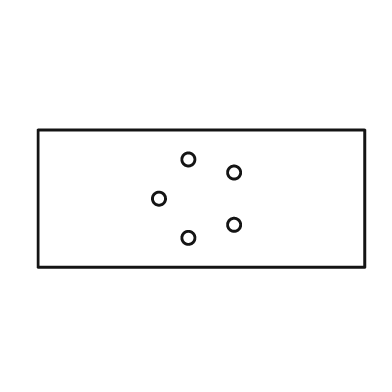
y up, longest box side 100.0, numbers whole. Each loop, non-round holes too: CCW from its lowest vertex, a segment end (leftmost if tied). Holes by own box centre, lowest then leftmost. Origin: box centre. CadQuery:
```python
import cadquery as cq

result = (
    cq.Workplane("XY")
    .moveTo(-50.0, -21.0)
    .lineTo(50.0, -21.0)
    .lineTo(50.0, 21.0)
    .lineTo(-50.0, 21.0)
    .close()
    .moveTo(-4.0, -12.0)
    .circle(2.0)
    .moveTo(10.0, -8.0)
    .circle(2.0)
    .moveTo(-13.0, 0.0)
    .circle(2.0)
    .moveTo(10.0, 8.0)
    .circle(2.0)
    .moveTo(-4.0, 12.0)
    .circle(2.0)
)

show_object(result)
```